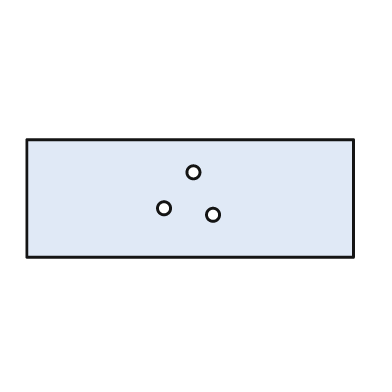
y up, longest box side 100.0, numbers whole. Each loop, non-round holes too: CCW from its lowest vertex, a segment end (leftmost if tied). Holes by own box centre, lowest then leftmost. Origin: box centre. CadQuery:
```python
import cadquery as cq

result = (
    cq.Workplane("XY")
    .moveTo(-50.0, -18.0)
    .lineTo(50.0, -18.0)
    .lineTo(50.0, 18.0)
    .lineTo(-50.0, 18.0)
    .close()
    .moveTo(7.0, -5.0)
    .circle(2.0)
    .moveTo(-8.0, -3.0)
    .circle(2.0)
    .moveTo(1.0, 8.0)
    .circle(2.0)
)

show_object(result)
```